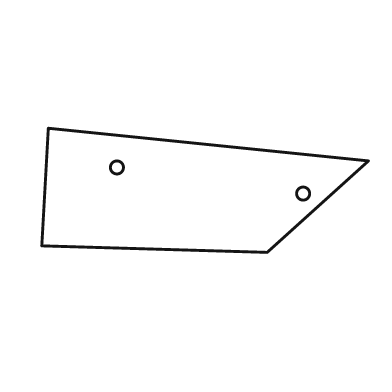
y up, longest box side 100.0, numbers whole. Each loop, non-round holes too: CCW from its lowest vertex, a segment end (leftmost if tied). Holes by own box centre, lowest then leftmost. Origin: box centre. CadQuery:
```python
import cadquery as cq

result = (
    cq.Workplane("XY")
    .moveTo(19.0, -19.0)
    .lineTo(50.0, 9.0)
    .lineTo(-48.0, 19.0)
    .lineTo(-50.0, -17.0)
    .close()
    .moveTo(30.0, -1.0)
    .circle(2.0)
    .moveTo(-27.0, 7.0)
    .circle(2.0)
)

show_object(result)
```